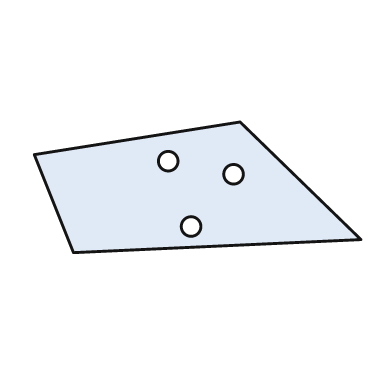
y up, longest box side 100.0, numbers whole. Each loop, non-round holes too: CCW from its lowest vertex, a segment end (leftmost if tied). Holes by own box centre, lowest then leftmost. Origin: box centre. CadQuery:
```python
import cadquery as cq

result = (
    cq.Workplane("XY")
    .moveTo(-38.0, -20.0)
    .lineTo(50.0, -16.0)
    .lineTo(13.0, 20.0)
    .lineTo(-50.0, 10.0)
    .close()
    .moveTo(-2.0, -12.0)
    .circle(3.0)
    .moveTo(11.0, 4.0)
    .circle(3.0)
    .moveTo(-9.0, 8.0)
    .circle(3.0)
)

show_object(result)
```